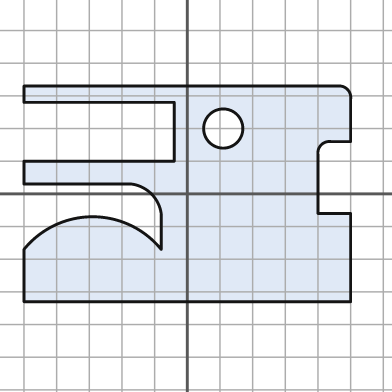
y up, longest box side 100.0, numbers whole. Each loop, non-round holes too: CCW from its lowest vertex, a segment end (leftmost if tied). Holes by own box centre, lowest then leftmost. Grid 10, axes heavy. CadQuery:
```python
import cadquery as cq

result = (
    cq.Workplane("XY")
    .moveTo(-50.0, -33.0)
    .lineTo(50.0, -33.0)
    .lineTo(50.0, -6.0)
    .lineTo(40.0, -6.0)
    .lineTo(40.0, 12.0)
    .threePointArc((41.0, 15.0), (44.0, 16.0))
    .lineTo(50.0, 16.0)
    .lineTo(50.0, 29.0)
    .threePointArc((49.0, 32.0), (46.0, 33.0))
    .lineTo(-50.0, 33.0)
    .lineTo(-50.0, 28.0)
    .lineTo(-4.0, 28.0)
    .lineTo(-4.0, 10.0)
    .lineTo(-50.0, 10.0)
    .lineTo(-50.0, 3.0)
    .lineTo(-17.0, 3.0)
    .threePointArc((-11.0, 0.0), (-8.0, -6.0))
    .lineTo(-8.0, -17.0)
    .threePointArc((-29.0, -7.0), (-50.0, -17.0))
    .close()
    .moveTo(11.0, 20.0)
    .circle(6.0)
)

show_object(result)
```